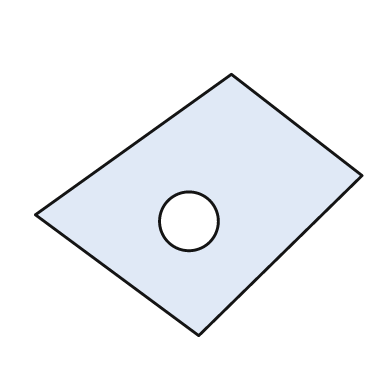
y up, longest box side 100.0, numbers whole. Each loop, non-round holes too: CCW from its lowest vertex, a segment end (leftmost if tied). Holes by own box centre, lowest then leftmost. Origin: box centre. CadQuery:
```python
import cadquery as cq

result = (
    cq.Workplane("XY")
    .moveTo(0.0, -40.0)
    .lineTo(50.0, 9.0)
    .lineTo(10.0, 40.0)
    .lineTo(-50.0, -3.0)
    .close()
    .moveTo(-3.0, -5.0)
    .circle(9.0)
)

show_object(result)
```